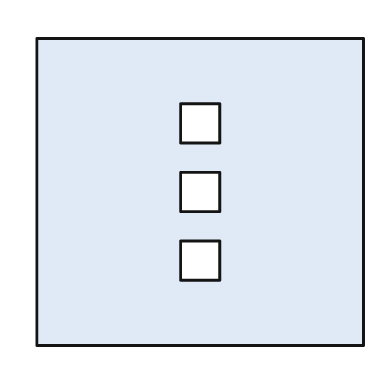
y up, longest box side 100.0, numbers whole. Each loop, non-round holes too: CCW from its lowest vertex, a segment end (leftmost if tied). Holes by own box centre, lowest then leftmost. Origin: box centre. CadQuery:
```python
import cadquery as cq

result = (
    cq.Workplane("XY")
    .moveTo(-50.0, -47.0)
    .lineTo(50.0, -47.0)
    .lineTo(50.0, 47.0)
    .lineTo(-50.0, 47.0)
    .close()
    .moveTo(-6.0, -27.0)
    .lineTo(6.0, -27.0)
    .lineTo(6.0, -15.0)
    .lineTo(-6.0, -15.0)
    .close()
    .moveTo(-6.0, -6.0)
    .lineTo(6.0, -6.0)
    .lineTo(6.0, 6.0)
    .lineTo(-6.0, 6.0)
    .close()
    .moveTo(-6.0, 15.0)
    .lineTo(6.0, 15.0)
    .lineTo(6.0, 27.0)
    .lineTo(-6.0, 27.0)
    .close()
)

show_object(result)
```